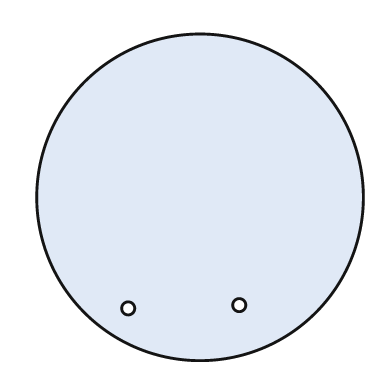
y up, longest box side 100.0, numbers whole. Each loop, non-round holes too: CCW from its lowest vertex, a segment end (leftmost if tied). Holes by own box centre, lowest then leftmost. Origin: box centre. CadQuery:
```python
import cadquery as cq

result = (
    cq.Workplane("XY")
    .moveTo(0.0, 0.0)
    .circle(50.0)
    .moveTo(-22.0, -34.0)
    .circle(2.0)
    .moveTo(12.0, -33.0)
    .circle(2.0)
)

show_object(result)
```